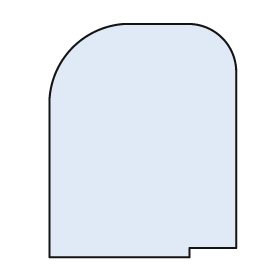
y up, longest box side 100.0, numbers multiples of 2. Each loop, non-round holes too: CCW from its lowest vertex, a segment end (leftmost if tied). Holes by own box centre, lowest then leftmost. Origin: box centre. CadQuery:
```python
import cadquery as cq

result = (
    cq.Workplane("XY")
    .moveTo(-40.0, -50.0)
    .lineTo(20.0, -50.0)
    .lineTo(20.0, -46.0)
    .lineTo(40.0, -46.0)
    .lineTo(40.0, 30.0)
    .threePointArc((34.0, 44.0), (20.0, 50.0))
    .lineTo(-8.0, 50.0)
    .threePointArc((-30.0, 40.0), (-40.0, 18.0))
    .close()
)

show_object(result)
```